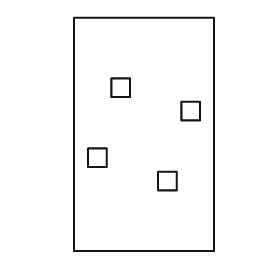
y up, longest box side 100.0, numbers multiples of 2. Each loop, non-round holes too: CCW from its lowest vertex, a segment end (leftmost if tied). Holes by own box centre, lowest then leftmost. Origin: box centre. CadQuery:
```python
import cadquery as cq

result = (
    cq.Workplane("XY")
    .moveTo(-30.0, -50.0)
    .lineTo(30.0, -50.0)
    .lineTo(30.0, 50.0)
    .lineTo(-30.0, 50.0)
    .close()
    .moveTo(6.0, -24.0)
    .lineTo(14.0, -24.0)
    .lineTo(14.0, -16.0)
    .lineTo(6.0, -16.0)
    .close()
    .moveTo(-24.0, -14.0)
    .lineTo(-16.0, -14.0)
    .lineTo(-16.0, -6.0)
    .lineTo(-24.0, -6.0)
    .close()
    .moveTo(16.0, 6.0)
    .lineTo(24.0, 6.0)
    .lineTo(24.0, 14.0)
    .lineTo(16.0, 14.0)
    .close()
    .moveTo(-14.0, 16.0)
    .lineTo(-6.0, 16.0)
    .lineTo(-6.0, 24.0)
    .lineTo(-14.0, 24.0)
    .close()
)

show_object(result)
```